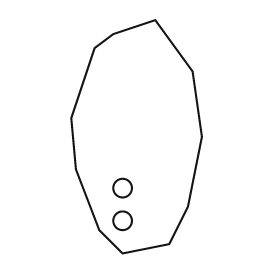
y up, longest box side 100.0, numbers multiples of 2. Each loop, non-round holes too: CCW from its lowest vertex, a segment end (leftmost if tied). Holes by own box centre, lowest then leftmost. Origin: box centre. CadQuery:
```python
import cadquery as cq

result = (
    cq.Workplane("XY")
    .moveTo(-6.0, -50.0)
    .lineTo(14.0, -46.0)
    .lineTo(22.0, -30.0)
    .lineTo(28.0, 0.0)
    .lineTo(24.0, 28.0)
    .lineTo(8.0, 50.0)
    .lineTo(-10.0, 44.0)
    .lineTo(-18.0, 38.0)
    .lineTo(-28.0, 8.0)
    .lineTo(-26.0, -14.0)
    .lineTo(-16.0, -40.0)
    .close()
    .moveTo(-6.0, -36.0)
    .circle(4.0)
    .moveTo(-6.0, -22.0)
    .circle(4.0)
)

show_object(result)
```